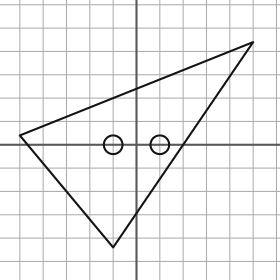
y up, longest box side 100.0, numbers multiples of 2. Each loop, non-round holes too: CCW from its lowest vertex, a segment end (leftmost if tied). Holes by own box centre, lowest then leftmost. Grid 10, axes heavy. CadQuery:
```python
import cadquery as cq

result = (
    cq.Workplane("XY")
    .moveTo(-10.0, -44.0)
    .lineTo(50.0, 44.0)
    .lineTo(-50.0, 4.0)
    .close()
    .moveTo(-10.0, 0.0)
    .circle(4.0)
    .moveTo(10.0, 0.0)
    .circle(4.0)
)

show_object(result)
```